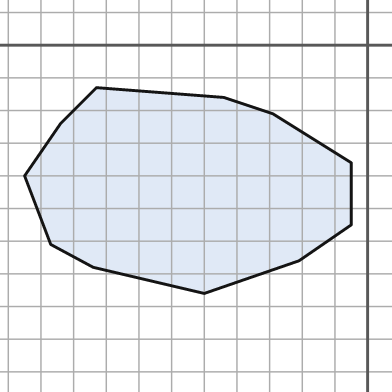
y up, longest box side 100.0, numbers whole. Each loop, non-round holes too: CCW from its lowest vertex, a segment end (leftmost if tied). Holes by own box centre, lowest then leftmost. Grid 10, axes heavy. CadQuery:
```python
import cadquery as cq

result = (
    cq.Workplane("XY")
    .moveTo(-50.0, -76.0)
    .lineTo(-21.0, -66.0)
    .lineTo(-5.0, -55.0)
    .lineTo(-5.0, -36.0)
    .lineTo(-29.0, -21.0)
    .lineTo(-44.0, -16.0)
    .lineTo(-83.0, -13.0)
    .lineTo(-94.0, -24.0)
    .lineTo(-105.0, -40.0)
    .lineTo(-97.0, -61.0)
    .lineTo(-84.0, -68.0)
    .close()
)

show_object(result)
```